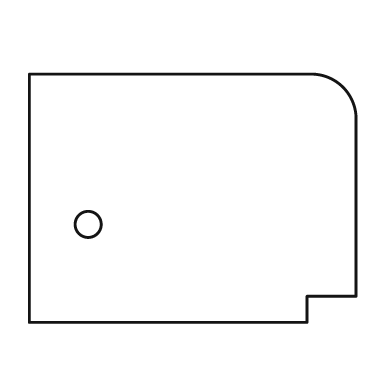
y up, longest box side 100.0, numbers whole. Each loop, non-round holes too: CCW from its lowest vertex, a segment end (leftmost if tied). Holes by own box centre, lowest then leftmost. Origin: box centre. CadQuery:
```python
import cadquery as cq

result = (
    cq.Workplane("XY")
    .moveTo(-50.0, -38.0)
    .lineTo(35.0, -38.0)
    .lineTo(35.0, -30.0)
    .lineTo(50.0, -30.0)
    .lineTo(50.0, 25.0)
    .threePointArc((46.0, 34.0), (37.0, 38.0))
    .lineTo(-50.0, 38.0)
    .close()
    .moveTo(-32.0, -8.0)
    .circle(4.0)
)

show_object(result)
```